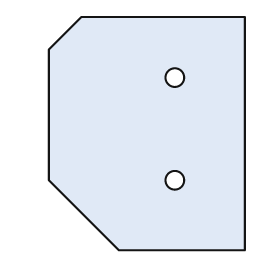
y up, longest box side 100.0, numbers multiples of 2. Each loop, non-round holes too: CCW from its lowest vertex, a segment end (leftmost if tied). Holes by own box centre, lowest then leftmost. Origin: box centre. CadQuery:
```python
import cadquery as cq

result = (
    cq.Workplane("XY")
    .moveTo(-12.0, -50.0)
    .lineTo(42.0, -50.0)
    .lineTo(42.0, 50.0)
    .lineTo(-28.0, 50.0)
    .lineTo(-42.0, 36.0)
    .lineTo(-42.0, -20.0)
    .close()
    .moveTo(12.0, -20.0)
    .circle(4.0)
    .moveTo(12.0, 24.0)
    .circle(4.0)
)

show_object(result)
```